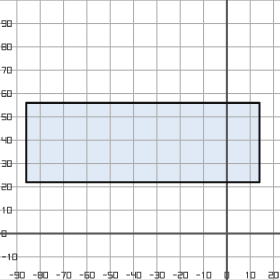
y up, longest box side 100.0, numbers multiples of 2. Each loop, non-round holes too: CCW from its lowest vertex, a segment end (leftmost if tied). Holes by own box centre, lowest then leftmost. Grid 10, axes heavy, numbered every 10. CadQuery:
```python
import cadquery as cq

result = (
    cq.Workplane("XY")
    .moveTo(-86.0, 22.0)
    .lineTo(14.0, 22.0)
    .lineTo(14.0, 56.0)
    .lineTo(-86.0, 56.0)
    .close()
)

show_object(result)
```